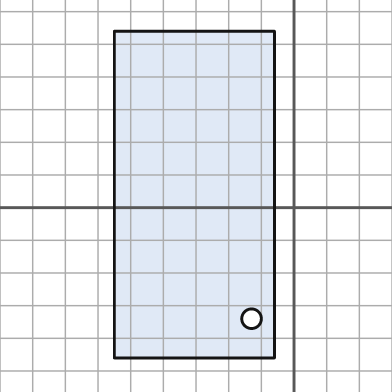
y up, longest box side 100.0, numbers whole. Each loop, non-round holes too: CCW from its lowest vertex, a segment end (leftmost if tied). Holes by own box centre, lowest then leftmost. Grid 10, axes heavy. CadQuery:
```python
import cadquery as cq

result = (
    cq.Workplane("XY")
    .moveTo(-55.0, -46.0)
    .lineTo(-6.0, -46.0)
    .lineTo(-6.0, 54.0)
    .lineTo(-55.0, 54.0)
    .close()
    .moveTo(-13.0, -34.0)
    .circle(3.0)
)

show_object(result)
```